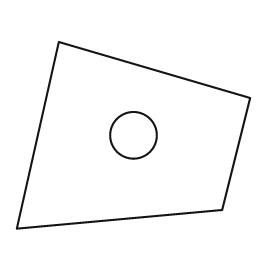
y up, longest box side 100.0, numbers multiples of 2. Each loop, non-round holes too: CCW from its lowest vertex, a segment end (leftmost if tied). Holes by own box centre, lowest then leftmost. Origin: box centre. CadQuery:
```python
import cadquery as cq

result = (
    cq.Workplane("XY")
    .moveTo(-50.0, -40.0)
    .lineTo(38.0, -32.0)
    .lineTo(50.0, 16.0)
    .lineTo(-32.0, 40.0)
    .close()
    .moveTo(0.0, 0.0)
    .circle(10.0)
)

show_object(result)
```